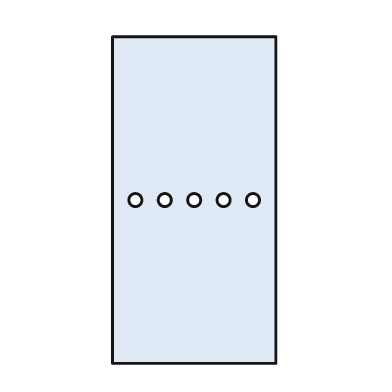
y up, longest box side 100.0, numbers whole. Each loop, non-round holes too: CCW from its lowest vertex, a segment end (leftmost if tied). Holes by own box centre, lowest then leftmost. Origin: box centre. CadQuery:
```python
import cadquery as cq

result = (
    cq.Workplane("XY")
    .moveTo(-25.0, -50.0)
    .lineTo(25.0, -50.0)
    .lineTo(25.0, 50.0)
    .lineTo(-25.0, 50.0)
    .close()
    .moveTo(-18.0, 0.0)
    .circle(2.0)
    .moveTo(-9.0, 0.0)
    .circle(2.0)
    .moveTo(0.0, 0.0)
    .circle(2.0)
    .moveTo(9.0, 0.0)
    .circle(2.0)
    .moveTo(18.0, 0.0)
    .circle(2.0)
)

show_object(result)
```